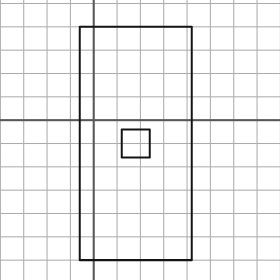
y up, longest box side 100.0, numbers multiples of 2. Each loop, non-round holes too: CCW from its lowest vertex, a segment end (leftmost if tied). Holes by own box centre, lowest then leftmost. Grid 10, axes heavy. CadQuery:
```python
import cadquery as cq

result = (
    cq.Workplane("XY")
    .moveTo(-6.0, -60.0)
    .lineTo(42.0, -60.0)
    .lineTo(42.0, 40.0)
    .lineTo(-6.0, 40.0)
    .close()
    .moveTo(12.0, -16.0)
    .lineTo(24.0, -16.0)
    .lineTo(24.0, -4.0)
    .lineTo(12.0, -4.0)
    .close()
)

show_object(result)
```